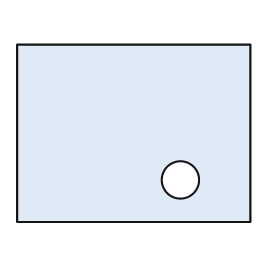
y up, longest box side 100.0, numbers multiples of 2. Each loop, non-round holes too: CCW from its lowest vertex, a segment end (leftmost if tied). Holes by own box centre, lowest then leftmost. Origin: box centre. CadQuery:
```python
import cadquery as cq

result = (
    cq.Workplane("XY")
    .moveTo(-50.0, -38.0)
    .lineTo(50.0, -38.0)
    .lineTo(50.0, 38.0)
    .lineTo(-50.0, 38.0)
    .close()
    .moveTo(20.0, -20.0)
    .circle(8.0)
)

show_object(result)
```